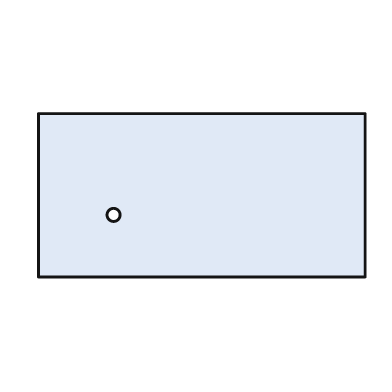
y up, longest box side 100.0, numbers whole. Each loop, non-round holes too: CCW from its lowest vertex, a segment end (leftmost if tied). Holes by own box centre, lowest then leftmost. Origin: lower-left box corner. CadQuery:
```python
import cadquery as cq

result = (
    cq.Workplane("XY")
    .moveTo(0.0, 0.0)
    .lineTo(100.0, 0.0)
    .lineTo(100.0, 50.0)
    .lineTo(0.0, 50.0)
    .close()
    .moveTo(23.0, 19.0)
    .circle(2.0)
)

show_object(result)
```